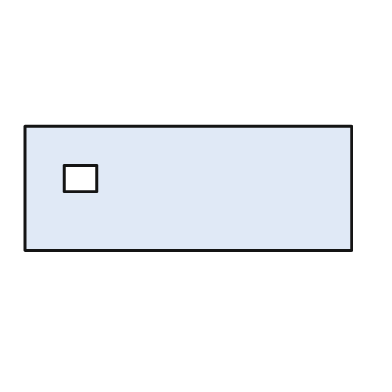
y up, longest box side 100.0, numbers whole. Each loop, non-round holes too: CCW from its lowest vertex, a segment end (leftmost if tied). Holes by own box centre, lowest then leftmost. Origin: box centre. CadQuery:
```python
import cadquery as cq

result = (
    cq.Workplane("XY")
    .moveTo(-50.0, -19.0)
    .lineTo(50.0, -19.0)
    .lineTo(50.0, 19.0)
    .lineTo(-50.0, 19.0)
    .close()
    .moveTo(-38.0, -1.0)
    .lineTo(-28.0, -1.0)
    .lineTo(-28.0, 7.0)
    .lineTo(-38.0, 7.0)
    .close()
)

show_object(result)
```